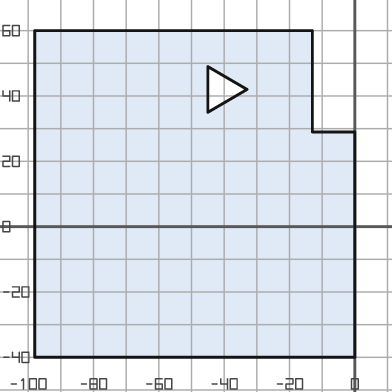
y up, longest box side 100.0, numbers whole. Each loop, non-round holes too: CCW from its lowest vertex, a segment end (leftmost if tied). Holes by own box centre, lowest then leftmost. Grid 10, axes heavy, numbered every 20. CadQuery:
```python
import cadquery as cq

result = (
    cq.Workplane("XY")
    .moveTo(-98.0, -40.0)
    .lineTo(0.0, -40.0)
    .lineTo(0.0, 29.0)
    .lineTo(-13.0, 29.0)
    .lineTo(-13.0, 60.0)
    .lineTo(-98.0, 60.0)
    .close()
    .moveTo(-45.0, 35.0)
    .lineTo(-33.0, 42.0)
    .lineTo(-45.0, 49.0)
    .close()
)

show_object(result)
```